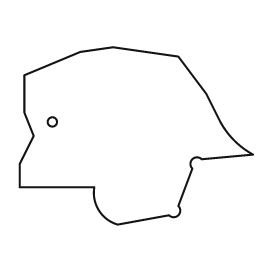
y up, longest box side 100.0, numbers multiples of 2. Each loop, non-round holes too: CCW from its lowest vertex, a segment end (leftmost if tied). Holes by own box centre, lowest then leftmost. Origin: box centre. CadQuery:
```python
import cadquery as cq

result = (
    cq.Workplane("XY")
    .moveTo(-8.0, -38.0)
    .lineTo(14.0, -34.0)
    .threePointArc((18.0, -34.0), (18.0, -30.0))
    .lineTo(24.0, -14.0)
    .threePointArc((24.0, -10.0), (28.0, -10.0))
    .lineTo(50.0, -8.0)
    .threePointArc((42.0, -2.0), (36.0, 6.0))
    .lineTo(30.0, 18.0)
    .lineTo(18.0, 34.0)
    .lineTo(-10.0, 38.0)
    .lineTo(-24.0, 36.0)
    .lineTo(-48.0, 26.0)
    .lineTo(-48.0, 10.0)
    .lineTo(-44.0, 0.0)
    .lineTo(-50.0, -12.0)
    .lineTo(-50.0, -22.0)
    .lineTo(-18.0, -22.0)
    .threePointArc((-16.0, -32.0), (-8.0, -38.0))
    .close()
    .moveTo(-36.0, 6.0)
    .circle(2.0)
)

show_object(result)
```